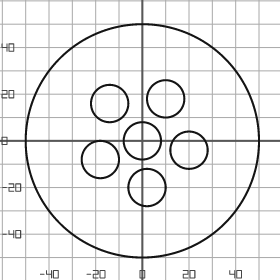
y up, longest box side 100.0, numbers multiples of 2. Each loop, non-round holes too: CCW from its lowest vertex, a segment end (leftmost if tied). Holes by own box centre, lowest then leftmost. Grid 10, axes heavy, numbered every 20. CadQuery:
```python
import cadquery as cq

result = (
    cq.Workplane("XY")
    .moveTo(0.0, 0.0)
    .circle(50.0)
    .moveTo(2.0, -20.0)
    .circle(8.0)
    .moveTo(-18.0, -8.0)
    .circle(8.0)
    .moveTo(20.0, -4.0)
    .circle(8.0)
    .moveTo(0.0, 0.0)
    .circle(8.0)
    .moveTo(-14.0, 16.0)
    .circle(8.0)
    .moveTo(10.0, 18.0)
    .circle(8.0)
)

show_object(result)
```